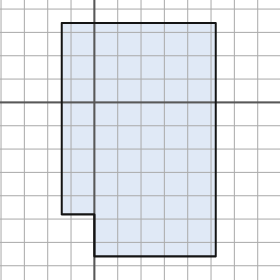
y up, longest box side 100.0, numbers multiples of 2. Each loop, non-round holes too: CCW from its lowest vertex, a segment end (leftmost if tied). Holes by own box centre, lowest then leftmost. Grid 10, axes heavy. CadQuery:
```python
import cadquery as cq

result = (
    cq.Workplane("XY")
    .moveTo(0.0, -66.0)
    .lineTo(52.0, -66.0)
    .lineTo(52.0, 34.0)
    .lineTo(-14.0, 34.0)
    .lineTo(-14.0, -48.0)
    .lineTo(0.0, -48.0)
    .close()
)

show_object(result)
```